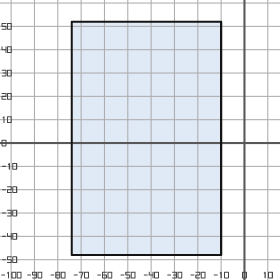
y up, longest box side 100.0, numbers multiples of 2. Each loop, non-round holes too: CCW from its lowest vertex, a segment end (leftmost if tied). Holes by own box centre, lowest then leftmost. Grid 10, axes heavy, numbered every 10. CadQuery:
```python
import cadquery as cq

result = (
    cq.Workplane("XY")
    .moveTo(-74.0, -48.0)
    .lineTo(-10.0, -48.0)
    .lineTo(-10.0, 52.0)
    .lineTo(-74.0, 52.0)
    .close()
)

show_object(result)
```